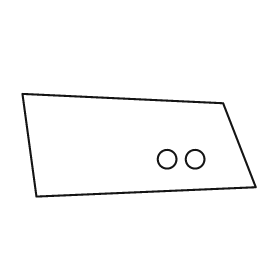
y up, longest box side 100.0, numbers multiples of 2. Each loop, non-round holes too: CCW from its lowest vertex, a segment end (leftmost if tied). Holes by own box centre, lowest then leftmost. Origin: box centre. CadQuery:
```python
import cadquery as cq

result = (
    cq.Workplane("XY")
    .moveTo(-44.0, -22.0)
    .lineTo(50.0, -18.0)
    .lineTo(36.0, 18.0)
    .lineTo(-50.0, 22.0)
    .close()
    .moveTo(12.0, -6.0)
    .circle(4.0)
    .moveTo(24.0, -6.0)
    .circle(4.0)
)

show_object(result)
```